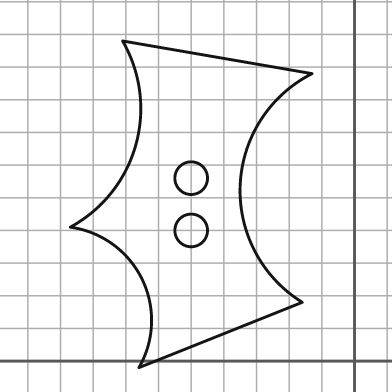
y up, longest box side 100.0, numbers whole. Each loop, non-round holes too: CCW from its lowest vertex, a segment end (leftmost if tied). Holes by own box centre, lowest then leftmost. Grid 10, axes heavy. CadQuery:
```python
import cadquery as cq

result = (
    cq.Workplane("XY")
    .moveTo(-66.0, -2.0)
    .lineTo(-16.0, 18.0)
    .threePointArc((-35.0, 54.0), (-13.0, 88.0))
    .lineTo(-71.0, 98.0)
    .threePointArc((-67.0, 66.0), (-87.0, 41.0))
    .threePointArc((-65.0, 25.0), (-66.0, -2.0))
    .close()
    .moveTo(-50.0, 40.0)
    .circle(5.0)
    .moveTo(-50.0, 56.0)
    .circle(5.0)
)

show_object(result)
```